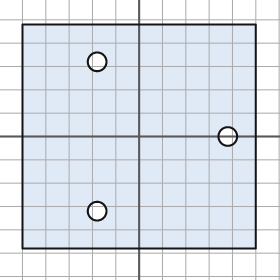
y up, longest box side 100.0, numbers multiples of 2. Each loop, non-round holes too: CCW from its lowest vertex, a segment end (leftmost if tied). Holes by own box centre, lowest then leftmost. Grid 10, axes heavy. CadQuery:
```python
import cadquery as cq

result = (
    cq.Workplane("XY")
    .moveTo(-50.0, -48.0)
    .lineTo(50.0, -48.0)
    .lineTo(50.0, 48.0)
    .lineTo(-50.0, 48.0)
    .close()
    .moveTo(-18.0, -32.0)
    .circle(4.0)
    .moveTo(38.0, 0.0)
    .circle(4.0)
    .moveTo(-18.0, 32.0)
    .circle(4.0)
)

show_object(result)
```